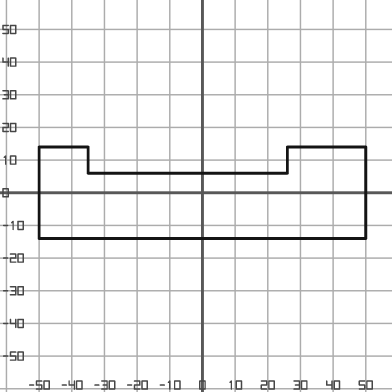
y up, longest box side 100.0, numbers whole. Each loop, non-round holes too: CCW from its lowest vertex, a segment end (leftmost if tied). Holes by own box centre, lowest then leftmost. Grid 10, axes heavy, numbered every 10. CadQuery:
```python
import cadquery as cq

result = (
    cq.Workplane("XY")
    .moveTo(-50.0, -14.0)
    .lineTo(50.0, -14.0)
    .lineTo(50.0, 14.0)
    .lineTo(26.0, 14.0)
    .lineTo(26.0, 6.0)
    .lineTo(-35.0, 6.0)
    .lineTo(-35.0, 14.0)
    .lineTo(-50.0, 14.0)
    .close()
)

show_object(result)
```